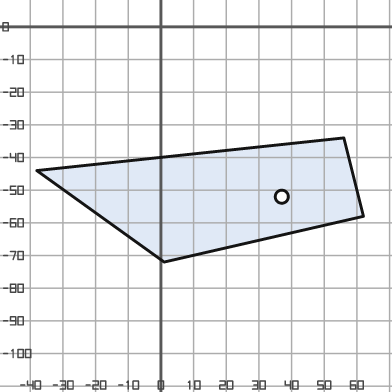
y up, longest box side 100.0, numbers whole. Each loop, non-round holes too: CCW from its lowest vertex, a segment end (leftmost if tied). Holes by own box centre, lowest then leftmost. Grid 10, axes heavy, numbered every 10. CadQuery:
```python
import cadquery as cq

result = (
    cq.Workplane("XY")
    .moveTo(1.0, -72.0)
    .lineTo(62.0, -58.0)
    .lineTo(56.0, -34.0)
    .lineTo(-38.0, -44.0)
    .close()
    .moveTo(37.0, -52.0)
    .circle(2.0)
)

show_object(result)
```